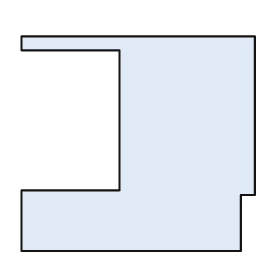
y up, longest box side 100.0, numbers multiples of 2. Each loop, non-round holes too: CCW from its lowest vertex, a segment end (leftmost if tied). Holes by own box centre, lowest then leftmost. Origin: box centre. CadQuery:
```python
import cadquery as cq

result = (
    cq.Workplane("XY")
    .moveTo(-50.0, -46.0)
    .lineTo(44.0, -46.0)
    .lineTo(44.0, -22.0)
    .lineTo(50.0, -22.0)
    .lineTo(50.0, 46.0)
    .lineTo(-50.0, 46.0)
    .lineTo(-50.0, 40.0)
    .lineTo(-8.0, 40.0)
    .lineTo(-8.0, -20.0)
    .lineTo(-50.0, -20.0)
    .close()
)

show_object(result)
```